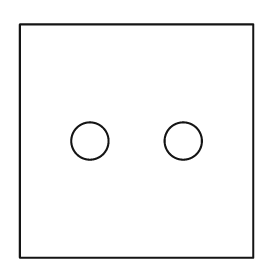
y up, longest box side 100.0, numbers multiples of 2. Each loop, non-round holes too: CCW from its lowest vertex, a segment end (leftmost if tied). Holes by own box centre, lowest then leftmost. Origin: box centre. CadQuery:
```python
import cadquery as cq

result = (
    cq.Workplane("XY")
    .moveTo(-50.0, -50.0)
    .lineTo(50.0, -50.0)
    .lineTo(50.0, 50.0)
    .lineTo(-50.0, 50.0)
    .close()
    .moveTo(-20.0, 0.0)
    .circle(8.0)
    .moveTo(20.0, 0.0)
    .circle(8.0)
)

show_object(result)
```